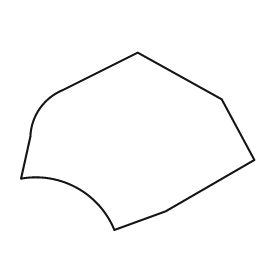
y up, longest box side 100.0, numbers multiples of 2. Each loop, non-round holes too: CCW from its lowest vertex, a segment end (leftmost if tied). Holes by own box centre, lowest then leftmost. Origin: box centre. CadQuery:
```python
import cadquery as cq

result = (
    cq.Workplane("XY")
    .moveTo(-10.0, -38.0)
    .lineTo(12.0, -30.0)
    .lineTo(50.0, -8.0)
    .lineTo(36.0, 18.0)
    .lineTo(0.0, 38.0)
    .lineTo(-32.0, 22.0)
    .threePointArc((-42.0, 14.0), (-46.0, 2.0))
    .lineTo(-50.0, -16.0)
    .threePointArc((-26.0, -20.0), (-10.0, -38.0))
    .close()
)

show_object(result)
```